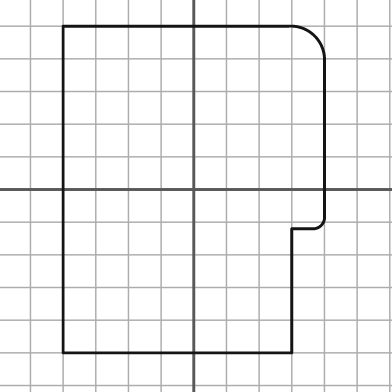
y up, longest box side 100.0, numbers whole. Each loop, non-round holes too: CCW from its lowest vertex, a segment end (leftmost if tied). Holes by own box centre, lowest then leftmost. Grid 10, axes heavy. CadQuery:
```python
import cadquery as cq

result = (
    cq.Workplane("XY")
    .moveTo(-40.0, -50.0)
    .lineTo(30.0, -50.0)
    .lineTo(30.0, -12.0)
    .lineTo(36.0, -12.0)
    .threePointArc((39.0, -11.0), (40.0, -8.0))
    .lineTo(40.0, 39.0)
    .threePointArc((37.0, 47.0), (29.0, 50.0))
    .lineTo(-40.0, 50.0)
    .close()
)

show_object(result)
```